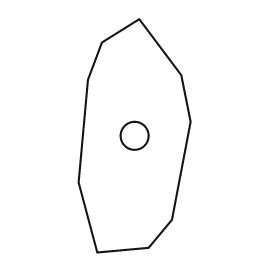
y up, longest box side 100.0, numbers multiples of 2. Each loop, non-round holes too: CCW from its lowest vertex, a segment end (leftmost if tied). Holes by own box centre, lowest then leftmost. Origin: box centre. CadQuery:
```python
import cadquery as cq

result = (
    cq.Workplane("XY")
    .moveTo(-16.0, -50.0)
    .lineTo(6.0, -48.0)
    .lineTo(16.0, -36.0)
    .lineTo(24.0, 6.0)
    .lineTo(20.0, 26.0)
    .lineTo(2.0, 50.0)
    .lineTo(-14.0, 40.0)
    .lineTo(-20.0, 24.0)
    .lineTo(-24.0, -20.0)
    .close()
    .moveTo(0.0, 0.0)
    .circle(6.0)
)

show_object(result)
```